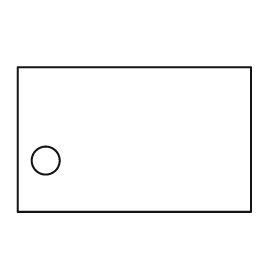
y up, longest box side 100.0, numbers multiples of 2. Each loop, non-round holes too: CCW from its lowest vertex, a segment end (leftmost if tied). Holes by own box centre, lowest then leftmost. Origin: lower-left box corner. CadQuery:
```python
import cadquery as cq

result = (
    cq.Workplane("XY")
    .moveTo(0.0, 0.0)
    .lineTo(100.0, 0.0)
    .lineTo(100.0, 62.0)
    .lineTo(0.0, 62.0)
    .close()
    .moveTo(12.0, 22.0)
    .circle(6.0)
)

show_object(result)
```